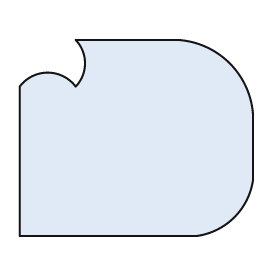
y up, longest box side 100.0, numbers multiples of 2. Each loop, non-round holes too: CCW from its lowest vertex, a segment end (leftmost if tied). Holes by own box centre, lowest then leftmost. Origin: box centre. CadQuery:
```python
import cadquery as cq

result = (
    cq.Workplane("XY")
    .moveTo(-50.0, -42.0)
    .lineTo(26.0, -42.0)
    .threePointArc((42.0, -34.0), (50.0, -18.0))
    .lineTo(50.0, 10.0)
    .threePointArc((40.0, 32.0), (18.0, 42.0))
    .lineTo(-26.0, 42.0)
    .threePointArc((-22.0, 32.0), (-26.0, 22.0))
    .threePointArc((-38.0, 28.0), (-50.0, 22.0))
    .close()
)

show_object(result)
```